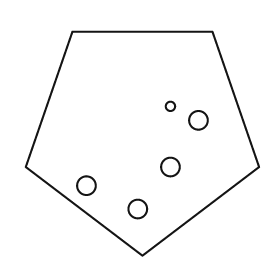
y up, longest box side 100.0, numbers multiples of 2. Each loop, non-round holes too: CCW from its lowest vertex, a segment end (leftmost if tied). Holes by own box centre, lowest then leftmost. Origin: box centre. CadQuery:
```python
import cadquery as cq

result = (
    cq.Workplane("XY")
    .moveTo(0.0, -48.0)
    .lineTo(50.0, -10.0)
    .lineTo(30.0, 48.0)
    .lineTo(-30.0, 48.0)
    .lineTo(-50.0, -10.0)
    .close()
    .moveTo(-2.0, -28.0)
    .circle(4.0)
    .moveTo(-24.0, -18.0)
    .circle(4.0)
    .moveTo(12.0, -10.0)
    .circle(4.0)
    .moveTo(24.0, 10.0)
    .circle(4.0)
    .moveTo(12.0, 16.0)
    .circle(2.0)
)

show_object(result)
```